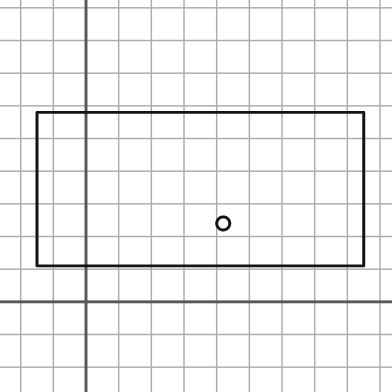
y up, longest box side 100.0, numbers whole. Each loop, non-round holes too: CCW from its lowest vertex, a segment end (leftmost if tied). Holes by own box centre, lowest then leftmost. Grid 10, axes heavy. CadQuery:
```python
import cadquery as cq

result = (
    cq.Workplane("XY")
    .moveTo(-15.0, 11.0)
    .lineTo(85.0, 11.0)
    .lineTo(85.0, 58.0)
    .lineTo(-15.0, 58.0)
    .close()
    .moveTo(42.0, 24.0)
    .circle(2.0)
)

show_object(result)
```